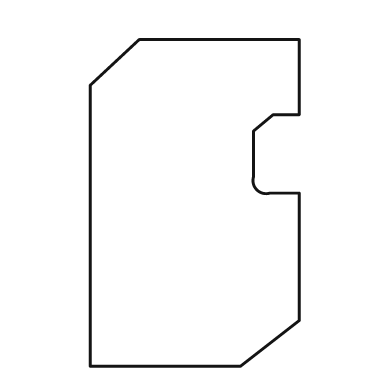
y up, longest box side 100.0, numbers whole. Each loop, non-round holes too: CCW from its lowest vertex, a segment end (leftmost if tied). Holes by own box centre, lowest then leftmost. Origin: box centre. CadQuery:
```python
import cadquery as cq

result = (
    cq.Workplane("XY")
    .moveTo(-32.0, -50.0)
    .lineTo(14.0, -50.0)
    .lineTo(32.0, -36.0)
    .lineTo(32.0, 3.0)
    .lineTo(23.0, 3.0)
    .threePointArc((19.0, 4.0), (18.0, 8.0))
    .lineTo(18.0, 22.0)
    .lineTo(24.0, 27.0)
    .lineTo(32.0, 27.0)
    .lineTo(32.0, 50.0)
    .lineTo(-17.0, 50.0)
    .lineTo(-32.0, 36.0)
    .close()
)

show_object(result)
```